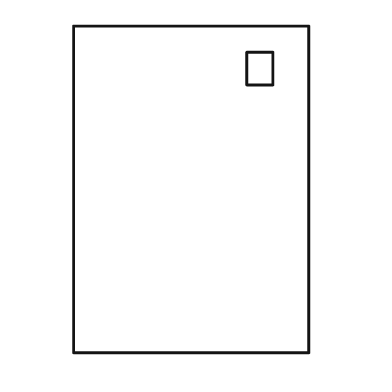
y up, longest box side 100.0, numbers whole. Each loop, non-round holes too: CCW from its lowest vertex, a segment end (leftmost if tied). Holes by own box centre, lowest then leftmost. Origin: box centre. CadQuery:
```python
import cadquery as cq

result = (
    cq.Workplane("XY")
    .moveTo(-36.0, -50.0)
    .lineTo(36.0, -50.0)
    .lineTo(36.0, 50.0)
    .lineTo(-36.0, 50.0)
    .close()
    .moveTo(17.0, 32.0)
    .lineTo(25.0, 32.0)
    .lineTo(25.0, 42.0)
    .lineTo(17.0, 42.0)
    .close()
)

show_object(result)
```